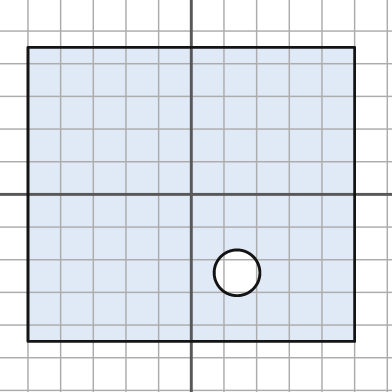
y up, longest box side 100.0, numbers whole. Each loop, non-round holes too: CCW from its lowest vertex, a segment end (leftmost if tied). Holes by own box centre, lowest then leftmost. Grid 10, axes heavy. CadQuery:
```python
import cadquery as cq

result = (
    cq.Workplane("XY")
    .moveTo(-50.0, -45.0)
    .lineTo(50.0, -45.0)
    .lineTo(50.0, 45.0)
    .lineTo(-50.0, 45.0)
    .close()
    .moveTo(14.0, -24.0)
    .circle(7.0)
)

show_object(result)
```